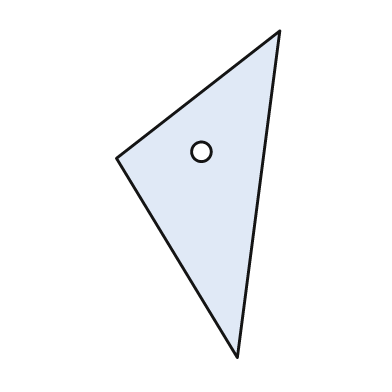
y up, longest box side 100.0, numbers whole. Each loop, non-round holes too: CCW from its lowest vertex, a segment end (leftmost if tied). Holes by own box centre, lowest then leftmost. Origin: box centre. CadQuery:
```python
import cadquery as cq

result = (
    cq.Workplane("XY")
    .moveTo(12.0, -50.0)
    .lineTo(25.0, 50.0)
    .lineTo(-25.0, 11.0)
    .close()
    .moveTo(1.0, 13.0)
    .circle(3.0)
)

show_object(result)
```